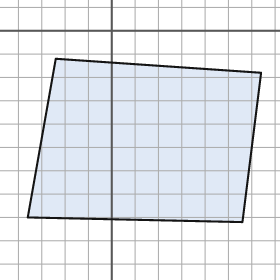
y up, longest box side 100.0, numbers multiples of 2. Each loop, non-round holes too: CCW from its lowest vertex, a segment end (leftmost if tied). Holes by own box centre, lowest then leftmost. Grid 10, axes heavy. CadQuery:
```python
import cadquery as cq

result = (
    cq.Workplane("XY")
    .moveTo(56.0, -82.0)
    .lineTo(64.0, -18.0)
    .lineTo(-24.0, -12.0)
    .lineTo(-36.0, -80.0)
    .close()
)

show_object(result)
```